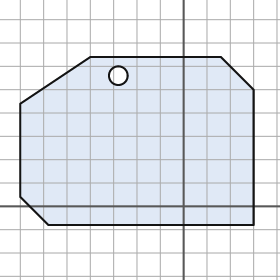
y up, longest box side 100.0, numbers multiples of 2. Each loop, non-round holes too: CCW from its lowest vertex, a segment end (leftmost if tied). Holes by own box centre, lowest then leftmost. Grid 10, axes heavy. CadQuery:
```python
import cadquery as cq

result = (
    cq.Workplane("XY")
    .moveTo(-58.0, -8.0)
    .lineTo(30.0, -8.0)
    .lineTo(30.0, 50.0)
    .lineTo(16.0, 64.0)
    .lineTo(-40.0, 64.0)
    .lineTo(-70.0, 44.0)
    .lineTo(-70.0, 4.0)
    .close()
    .moveTo(-28.0, 56.0)
    .circle(4.0)
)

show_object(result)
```